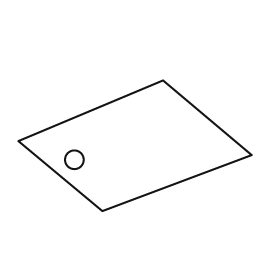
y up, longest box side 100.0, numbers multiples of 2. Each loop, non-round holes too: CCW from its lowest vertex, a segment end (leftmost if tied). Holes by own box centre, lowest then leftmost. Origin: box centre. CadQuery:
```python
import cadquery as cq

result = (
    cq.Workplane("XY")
    .moveTo(-14.0, -28.0)
    .lineTo(50.0, -4.0)
    .lineTo(12.0, 28.0)
    .lineTo(-50.0, 2.0)
    .close()
    .moveTo(-26.0, -6.0)
    .circle(4.0)
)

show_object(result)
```